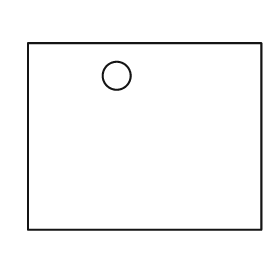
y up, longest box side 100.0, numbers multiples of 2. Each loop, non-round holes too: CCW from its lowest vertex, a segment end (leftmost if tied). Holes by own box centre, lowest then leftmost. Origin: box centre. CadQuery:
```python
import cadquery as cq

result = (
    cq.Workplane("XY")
    .moveTo(-50.0, -40.0)
    .lineTo(50.0, -40.0)
    .lineTo(50.0, 40.0)
    .lineTo(-50.0, 40.0)
    .close()
    .moveTo(-12.0, 26.0)
    .circle(6.0)
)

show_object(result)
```